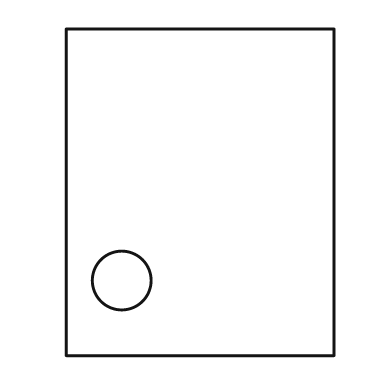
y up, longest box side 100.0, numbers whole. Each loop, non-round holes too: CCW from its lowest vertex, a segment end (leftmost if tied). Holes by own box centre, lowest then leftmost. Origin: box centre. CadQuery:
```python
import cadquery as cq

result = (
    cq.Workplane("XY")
    .moveTo(-41.0, -50.0)
    .lineTo(41.0, -50.0)
    .lineTo(41.0, 50.0)
    .lineTo(-41.0, 50.0)
    .close()
    .moveTo(-24.0, -27.0)
    .circle(9.0)
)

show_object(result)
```